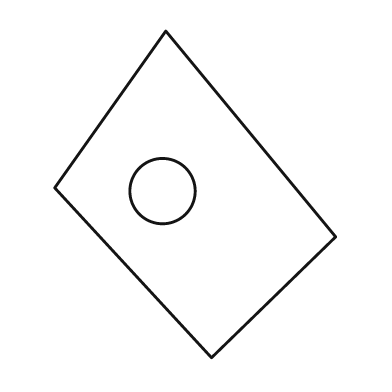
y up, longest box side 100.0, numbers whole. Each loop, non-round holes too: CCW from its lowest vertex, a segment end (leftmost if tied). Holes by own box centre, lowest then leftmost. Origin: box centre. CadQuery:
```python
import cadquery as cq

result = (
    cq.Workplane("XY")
    .moveTo(5.0, -50.0)
    .lineTo(43.0, -13.0)
    .lineTo(-9.0, 50.0)
    .lineTo(-43.0, 2.0)
    .close()
    .moveTo(-10.0, 1.0)
    .circle(10.0)
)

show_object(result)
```